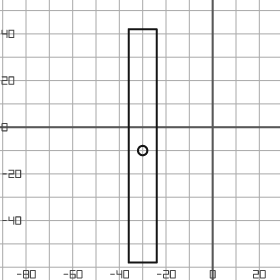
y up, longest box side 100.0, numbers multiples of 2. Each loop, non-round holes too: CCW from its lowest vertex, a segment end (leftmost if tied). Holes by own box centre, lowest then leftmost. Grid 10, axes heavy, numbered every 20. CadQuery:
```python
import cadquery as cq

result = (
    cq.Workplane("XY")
    .moveTo(-36.0, -58.0)
    .lineTo(-24.0, -58.0)
    .lineTo(-24.0, 42.0)
    .lineTo(-36.0, 42.0)
    .close()
    .moveTo(-30.0, -10.0)
    .circle(2.0)
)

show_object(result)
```